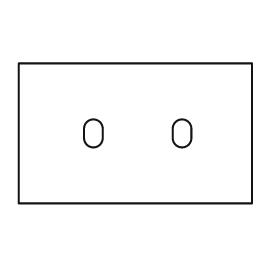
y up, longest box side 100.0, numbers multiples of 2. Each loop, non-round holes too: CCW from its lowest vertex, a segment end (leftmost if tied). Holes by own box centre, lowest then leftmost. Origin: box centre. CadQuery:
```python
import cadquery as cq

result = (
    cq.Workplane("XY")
    .moveTo(-50.0, -30.0)
    .lineTo(50.0, -30.0)
    .lineTo(50.0, 30.0)
    .lineTo(-50.0, 30.0)
    .close()
    .moveTo(-22.0, -2.0)
    .threePointArc((-18.0, -6.0), (-14.0, -2.0))
    .lineTo(-14.0, 2.0)
    .threePointArc((-18.0, 6.0), (-22.0, 2.0))
    .close()
    .moveTo(16.0, -2.0)
    .threePointArc((20.0, -6.0), (24.0, -2.0))
    .lineTo(24.0, 2.0)
    .threePointArc((20.0, 6.0), (16.0, 2.0))
    .close()
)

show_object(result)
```